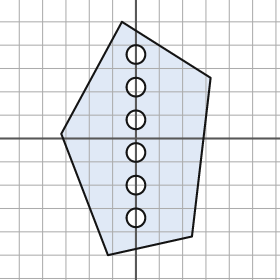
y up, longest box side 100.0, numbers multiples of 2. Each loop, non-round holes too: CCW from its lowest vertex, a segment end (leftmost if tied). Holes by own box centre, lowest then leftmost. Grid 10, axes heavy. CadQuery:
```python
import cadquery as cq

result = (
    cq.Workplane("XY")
    .moveTo(-12.0, -50.0)
    .lineTo(24.0, -42.0)
    .lineTo(32.0, 26.0)
    .lineTo(-6.0, 50.0)
    .lineTo(-32.0, 2.0)
    .close()
    .moveTo(0.0, -34.0)
    .circle(4.0)
    .moveTo(0.0, -20.0)
    .circle(4.0)
    .moveTo(0.0, -6.0)
    .circle(4.0)
    .moveTo(0.0, 8.0)
    .circle(4.0)
    .moveTo(0.0, 22.0)
    .circle(4.0)
    .moveTo(0.0, 36.0)
    .circle(4.0)
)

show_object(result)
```